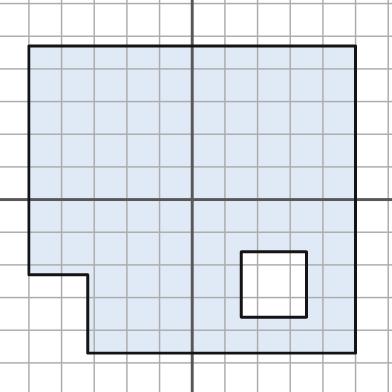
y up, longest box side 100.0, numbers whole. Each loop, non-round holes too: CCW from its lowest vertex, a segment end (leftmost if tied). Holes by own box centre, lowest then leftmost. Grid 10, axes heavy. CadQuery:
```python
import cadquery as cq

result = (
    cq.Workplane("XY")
    .moveTo(-32.0, -47.0)
    .lineTo(50.0, -47.0)
    .lineTo(50.0, 47.0)
    .lineTo(-50.0, 47.0)
    .lineTo(-50.0, -23.0)
    .lineTo(-32.0, -23.0)
    .close()
    .moveTo(15.0, -36.0)
    .lineTo(35.0, -36.0)
    .lineTo(35.0, -16.0)
    .lineTo(15.0, -16.0)
    .close()
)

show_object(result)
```